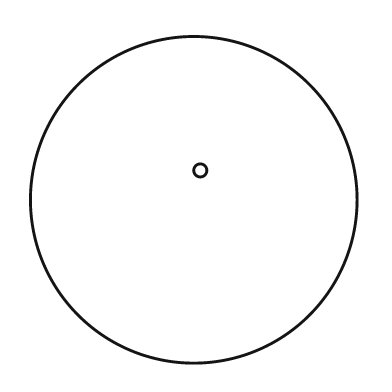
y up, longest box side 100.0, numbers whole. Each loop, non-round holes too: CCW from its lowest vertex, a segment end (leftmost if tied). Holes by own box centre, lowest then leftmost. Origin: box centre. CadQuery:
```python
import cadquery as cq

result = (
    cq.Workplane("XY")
    .moveTo(0.0, 0.0)
    .circle(50.0)
    .moveTo(2.0, 9.0)
    .circle(2.0)
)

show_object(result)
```